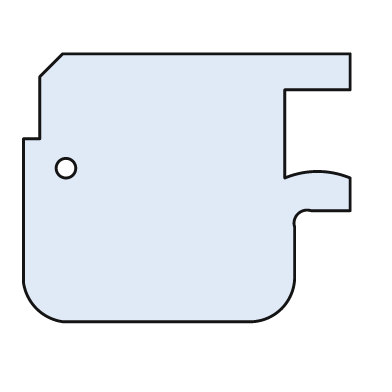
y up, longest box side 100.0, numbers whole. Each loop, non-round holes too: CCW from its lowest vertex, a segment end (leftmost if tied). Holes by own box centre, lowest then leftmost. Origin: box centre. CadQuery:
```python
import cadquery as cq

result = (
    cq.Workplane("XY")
    .moveTo(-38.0, -41.0)
    .lineTo(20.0, -41.0)
    .threePointArc((29.0, -37.0), (33.0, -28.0))
    .lineTo(33.0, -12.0)
    .threePointArc((34.0, -8.0), (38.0, -7.0))
    .lineTo(50.0, -7.0)
    .lineTo(50.0, 3.0)
    .threePointArc((40.0, 5.0), (30.0, 3.0))
    .lineTo(30.0, 30.0)
    .lineTo(50.0, 30.0)
    .lineTo(50.0, 41.0)
    .lineTo(-38.0, 41.0)
    .lineTo(-45.0, 34.0)
    .lineTo(-45.0, 15.0)
    .lineTo(-50.0, 15.0)
    .lineTo(-50.0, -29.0)
    .threePointArc((-46.0, -37.0), (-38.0, -41.0))
    .close()
    .moveTo(-37.0, 6.0)
    .circle(3.0)
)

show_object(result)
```